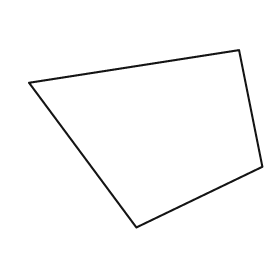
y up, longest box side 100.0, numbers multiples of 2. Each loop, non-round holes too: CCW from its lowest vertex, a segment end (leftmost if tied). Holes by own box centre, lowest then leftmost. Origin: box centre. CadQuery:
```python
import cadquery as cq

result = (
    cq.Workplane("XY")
    .moveTo(-4.0, -38.0)
    .lineTo(50.0, -12.0)
    .lineTo(40.0, 38.0)
    .lineTo(-50.0, 24.0)
    .close()
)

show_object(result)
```